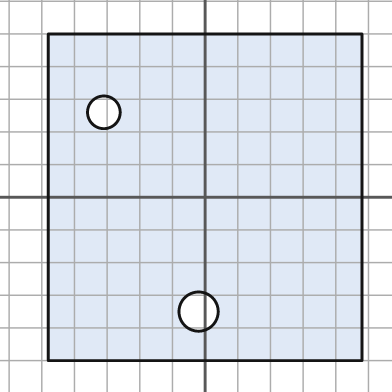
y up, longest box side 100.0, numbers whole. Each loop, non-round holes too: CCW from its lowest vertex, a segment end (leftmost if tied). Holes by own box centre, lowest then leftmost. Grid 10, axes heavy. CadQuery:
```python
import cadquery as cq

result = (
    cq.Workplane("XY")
    .moveTo(-48.0, -50.0)
    .lineTo(48.0, -50.0)
    .lineTo(48.0, 50.0)
    .lineTo(-48.0, 50.0)
    .close()
    .moveTo(-2.0, -35.0)
    .circle(6.0)
    .moveTo(-31.0, 26.0)
    .circle(5.0)
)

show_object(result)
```